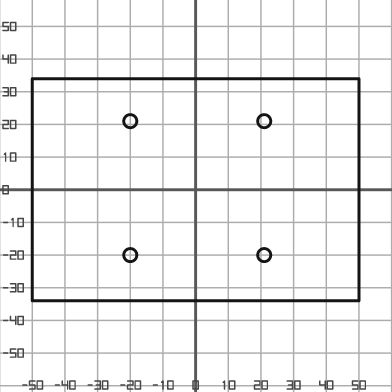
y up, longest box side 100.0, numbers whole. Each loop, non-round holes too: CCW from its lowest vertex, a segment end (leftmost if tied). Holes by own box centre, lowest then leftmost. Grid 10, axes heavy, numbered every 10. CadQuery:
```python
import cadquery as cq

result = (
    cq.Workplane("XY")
    .moveTo(-50.0, -34.0)
    .lineTo(50.0, -34.0)
    .lineTo(50.0, 34.0)
    .lineTo(-50.0, 34.0)
    .close()
    .moveTo(-20.0, -20.0)
    .circle(2.0)
    .moveTo(21.0, -20.0)
    .circle(2.0)
    .moveTo(-20.0, 21.0)
    .circle(2.0)
    .moveTo(21.0, 21.0)
    .circle(2.0)
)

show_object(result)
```